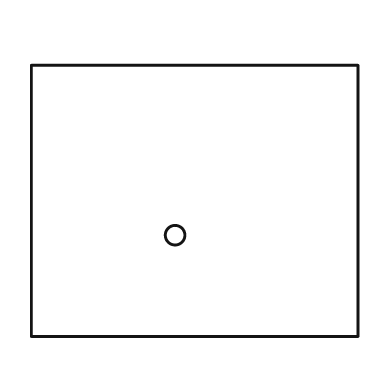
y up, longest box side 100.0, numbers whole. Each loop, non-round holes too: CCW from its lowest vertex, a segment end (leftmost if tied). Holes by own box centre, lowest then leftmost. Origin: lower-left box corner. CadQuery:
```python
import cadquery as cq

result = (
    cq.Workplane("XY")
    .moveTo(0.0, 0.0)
    .lineTo(100.0, 0.0)
    .lineTo(100.0, 83.0)
    .lineTo(0.0, 83.0)
    .close()
    .moveTo(44.0, 31.0)
    .circle(3.0)
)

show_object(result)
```